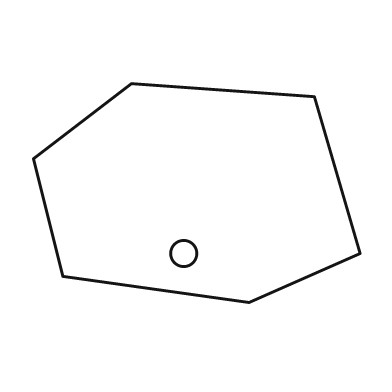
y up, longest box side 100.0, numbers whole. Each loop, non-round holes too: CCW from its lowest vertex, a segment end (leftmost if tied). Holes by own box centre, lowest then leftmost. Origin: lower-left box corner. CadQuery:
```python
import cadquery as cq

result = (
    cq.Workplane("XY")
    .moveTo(66.0, 0.0)
    .lineTo(100.0, 15.0)
    .lineTo(86.0, 63.0)
    .lineTo(30.0, 67.0)
    .lineTo(0.0, 44.0)
    .lineTo(9.0, 8.0)
    .close()
    .moveTo(46.0, 15.0)
    .circle(4.0)
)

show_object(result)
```